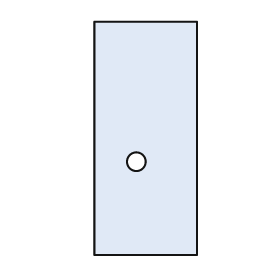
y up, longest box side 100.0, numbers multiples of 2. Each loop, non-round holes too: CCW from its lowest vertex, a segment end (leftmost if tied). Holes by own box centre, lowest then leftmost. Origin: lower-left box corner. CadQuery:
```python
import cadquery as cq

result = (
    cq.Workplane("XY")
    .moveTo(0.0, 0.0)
    .lineTo(44.0, 0.0)
    .lineTo(44.0, 100.0)
    .lineTo(0.0, 100.0)
    .close()
    .moveTo(18.0, 40.0)
    .circle(4.0)
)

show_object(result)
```